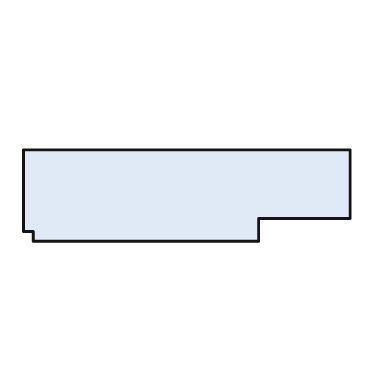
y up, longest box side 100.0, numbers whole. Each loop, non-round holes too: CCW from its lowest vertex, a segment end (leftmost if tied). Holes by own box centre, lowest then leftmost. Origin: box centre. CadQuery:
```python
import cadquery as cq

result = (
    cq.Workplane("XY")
    .moveTo(-47.0, -14.0)
    .lineTo(22.0, -14.0)
    .lineTo(22.0, -7.0)
    .lineTo(50.0, -7.0)
    .lineTo(50.0, 14.0)
    .lineTo(-50.0, 14.0)
    .lineTo(-50.0, -11.0)
    .lineTo(-47.0, -11.0)
    .close()
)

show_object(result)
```